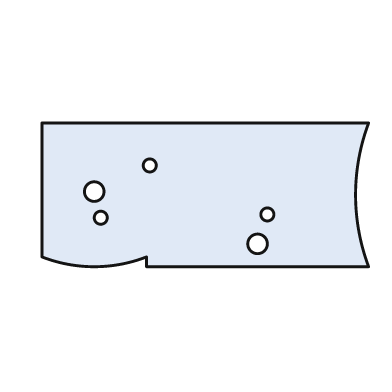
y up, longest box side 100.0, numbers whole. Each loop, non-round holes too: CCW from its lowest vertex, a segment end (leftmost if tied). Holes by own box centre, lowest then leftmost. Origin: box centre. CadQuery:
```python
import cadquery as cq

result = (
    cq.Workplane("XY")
    .moveTo(-18.0, -22.0)
    .lineTo(50.0, -22.0)
    .threePointArc((46.0, 0.0), (50.0, 22.0))
    .lineTo(-50.0, 22.0)
    .lineTo(-50.0, -19.0)
    .threePointArc((-34.0, -22.0), (-18.0, -19.0))
    .close()
    .moveTo(16.0, -15.0)
    .circle(3.0)
    .moveTo(-32.0, -7.0)
    .circle(2.0)
    .moveTo(19.0, -6.0)
    .circle(2.0)
    .moveTo(-34.0, 1.0)
    .circle(3.0)
    .moveTo(-17.0, 9.0)
    .circle(2.0)
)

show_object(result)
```